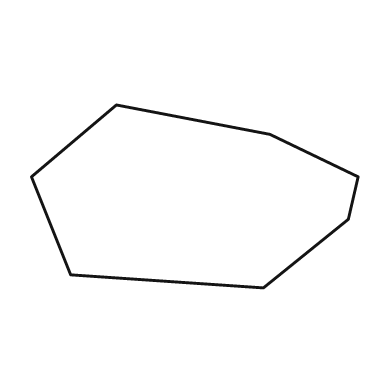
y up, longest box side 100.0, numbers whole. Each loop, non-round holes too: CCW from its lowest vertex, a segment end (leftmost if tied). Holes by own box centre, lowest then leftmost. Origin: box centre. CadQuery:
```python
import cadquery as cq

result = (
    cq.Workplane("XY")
    .moveTo(21.0, -28.0)
    .lineTo(47.0, -7.0)
    .lineTo(50.0, 6.0)
    .lineTo(23.0, 19.0)
    .lineTo(-24.0, 28.0)
    .lineTo(-50.0, 6.0)
    .lineTo(-38.0, -24.0)
    .close()
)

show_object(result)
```